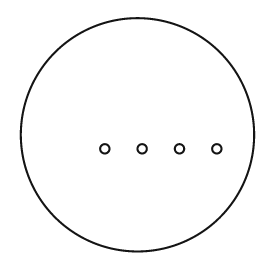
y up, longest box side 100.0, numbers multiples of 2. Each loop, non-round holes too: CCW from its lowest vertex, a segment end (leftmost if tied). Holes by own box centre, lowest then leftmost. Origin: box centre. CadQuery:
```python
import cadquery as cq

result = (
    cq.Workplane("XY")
    .moveTo(0.0, 0.0)
    .circle(50.0)
    .moveTo(-14.0, -6.0)
    .circle(2.0)
    .moveTo(2.0, -6.0)
    .circle(2.0)
    .moveTo(18.0, -6.0)
    .circle(2.0)
    .moveTo(34.0, -6.0)
    .circle(2.0)
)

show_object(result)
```